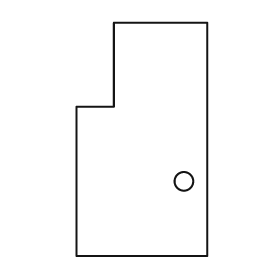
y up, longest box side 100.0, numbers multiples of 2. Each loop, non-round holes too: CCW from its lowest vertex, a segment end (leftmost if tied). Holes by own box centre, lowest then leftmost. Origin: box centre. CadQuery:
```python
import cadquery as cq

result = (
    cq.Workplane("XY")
    .moveTo(-28.0, -50.0)
    .lineTo(28.0, -50.0)
    .lineTo(28.0, 50.0)
    .lineTo(-12.0, 50.0)
    .lineTo(-12.0, 14.0)
    .lineTo(-28.0, 14.0)
    .close()
    .moveTo(18.0, -18.0)
    .circle(4.0)
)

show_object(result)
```